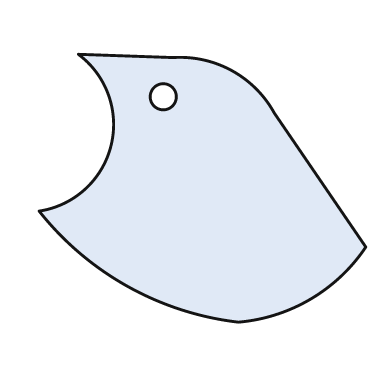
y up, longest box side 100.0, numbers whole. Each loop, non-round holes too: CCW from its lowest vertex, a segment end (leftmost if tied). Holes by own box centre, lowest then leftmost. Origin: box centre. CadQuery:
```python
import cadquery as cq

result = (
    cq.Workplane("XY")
    .moveTo(11.0, -41.0)
    .threePointArc((33.0, -34.0), (50.0, -18.0))
    .lineTo(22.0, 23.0)
    .threePointArc((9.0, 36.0), (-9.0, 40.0))
    .lineTo(-38.0, 41.0)
    .threePointArc((-28.0, 13.0), (-50.0, -7.0))
    .threePointArc((-23.0, -30.0), (11.0, -41.0))
    .close()
    .moveTo(-12.0, 28.0)
    .circle(4.0)
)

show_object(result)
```